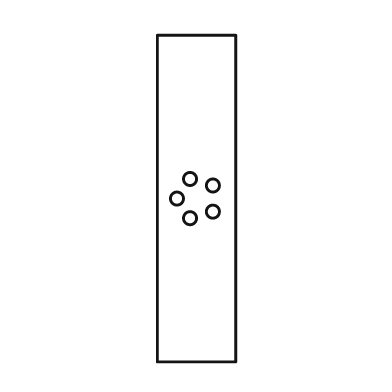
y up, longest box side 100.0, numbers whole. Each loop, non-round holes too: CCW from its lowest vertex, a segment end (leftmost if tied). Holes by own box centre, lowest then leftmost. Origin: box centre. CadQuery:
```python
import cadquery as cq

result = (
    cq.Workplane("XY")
    .moveTo(-12.0, -50.0)
    .lineTo(12.0, -50.0)
    .lineTo(12.0, 50.0)
    .lineTo(-12.0, 50.0)
    .close()
    .moveTo(-2.0, -6.0)
    .circle(2.0)
    .moveTo(5.0, -4.0)
    .circle(2.0)
    .moveTo(-6.0, 0.0)
    .circle(2.0)
    .moveTo(5.0, 4.0)
    .circle(2.0)
    .moveTo(-2.0, 6.0)
    .circle(2.0)
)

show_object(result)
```